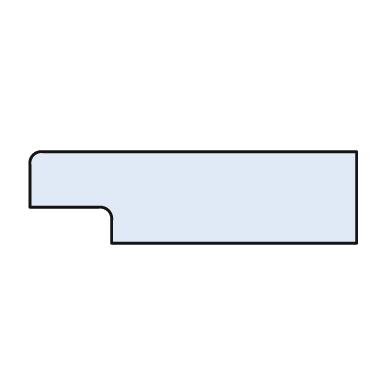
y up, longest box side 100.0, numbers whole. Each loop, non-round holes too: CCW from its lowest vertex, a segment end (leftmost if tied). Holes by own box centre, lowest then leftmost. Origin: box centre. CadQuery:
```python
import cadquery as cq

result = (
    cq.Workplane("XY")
    .moveTo(-25.0, -14.0)
    .lineTo(50.0, -14.0)
    .lineTo(50.0, 14.0)
    .lineTo(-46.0, 14.0)
    .threePointArc((-49.0, 13.0), (-50.0, 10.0))
    .lineTo(-50.0, -3.0)
    .lineTo(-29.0, -3.0)
    .threePointArc((-26.0, -4.0), (-25.0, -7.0))
    .close()
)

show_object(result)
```